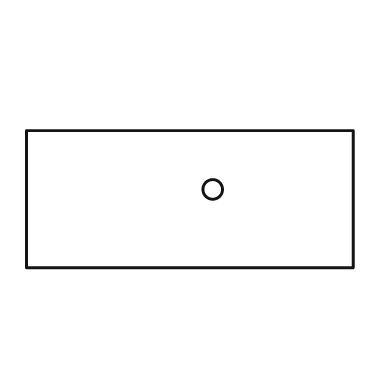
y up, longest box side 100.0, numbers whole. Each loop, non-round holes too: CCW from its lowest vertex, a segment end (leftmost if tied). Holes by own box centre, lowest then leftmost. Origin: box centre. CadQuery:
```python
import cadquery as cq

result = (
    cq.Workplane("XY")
    .moveTo(-50.0, -21.0)
    .lineTo(50.0, -21.0)
    .lineTo(50.0, 21.0)
    .lineTo(-50.0, 21.0)
    .close()
    .moveTo(7.0, 3.0)
    .circle(3.0)
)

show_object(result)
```